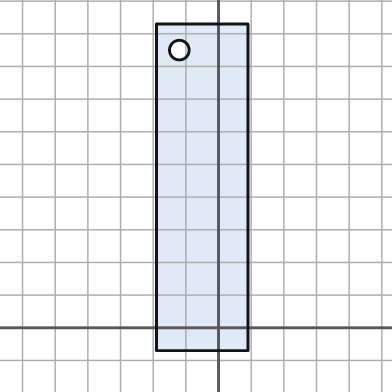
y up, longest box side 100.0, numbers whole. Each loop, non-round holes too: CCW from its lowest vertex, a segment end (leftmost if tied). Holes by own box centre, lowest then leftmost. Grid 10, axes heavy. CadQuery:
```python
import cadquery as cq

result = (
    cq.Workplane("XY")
    .moveTo(-19.0, -7.0)
    .lineTo(9.0, -7.0)
    .lineTo(9.0, 93.0)
    .lineTo(-19.0, 93.0)
    .close()
    .moveTo(-12.0, 85.0)
    .circle(3.0)
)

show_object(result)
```